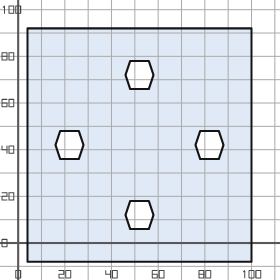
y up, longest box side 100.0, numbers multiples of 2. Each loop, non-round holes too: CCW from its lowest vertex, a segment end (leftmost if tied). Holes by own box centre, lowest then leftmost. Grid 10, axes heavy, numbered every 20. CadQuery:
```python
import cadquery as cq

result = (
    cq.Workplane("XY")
    .moveTo(4.0, -8.0)
    .lineTo(100.0, -8.0)
    .lineTo(100.0, 92.0)
    .lineTo(4.0, 92.0)
    .close()
    .moveTo(48.0, 6.0)
    .lineTo(56.0, 6.0)
    .lineTo(58.0, 12.0)
    .lineTo(56.0, 18.0)
    .lineTo(48.0, 18.0)
    .lineTo(46.0, 12.0)
    .close()
    .moveTo(18.0, 36.0)
    .lineTo(26.0, 36.0)
    .lineTo(28.0, 42.0)
    .lineTo(26.0, 48.0)
    .lineTo(18.0, 48.0)
    .lineTo(16.0, 42.0)
    .close()
    .moveTo(78.0, 36.0)
    .lineTo(86.0, 36.0)
    .lineTo(88.0, 42.0)
    .lineTo(86.0, 48.0)
    .lineTo(78.0, 48.0)
    .lineTo(76.0, 42.0)
    .close()
    .moveTo(48.0, 66.0)
    .lineTo(56.0, 66.0)
    .lineTo(58.0, 72.0)
    .lineTo(56.0, 78.0)
    .lineTo(48.0, 78.0)
    .lineTo(46.0, 72.0)
    .close()
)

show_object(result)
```